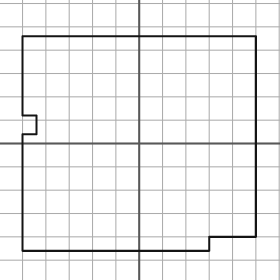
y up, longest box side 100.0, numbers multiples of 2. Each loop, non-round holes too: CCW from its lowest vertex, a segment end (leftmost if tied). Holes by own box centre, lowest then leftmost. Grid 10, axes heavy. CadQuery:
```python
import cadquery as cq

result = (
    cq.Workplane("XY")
    .moveTo(-50.0, -46.0)
    .lineTo(30.0, -46.0)
    .lineTo(30.0, -40.0)
    .lineTo(50.0, -40.0)
    .lineTo(50.0, 46.0)
    .lineTo(-50.0, 46.0)
    .lineTo(-50.0, 12.0)
    .lineTo(-44.0, 12.0)
    .lineTo(-44.0, 4.0)
    .lineTo(-50.0, 4.0)
    .close()
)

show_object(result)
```